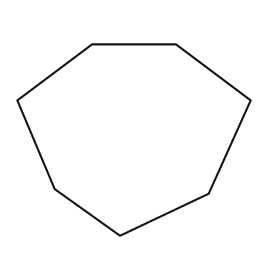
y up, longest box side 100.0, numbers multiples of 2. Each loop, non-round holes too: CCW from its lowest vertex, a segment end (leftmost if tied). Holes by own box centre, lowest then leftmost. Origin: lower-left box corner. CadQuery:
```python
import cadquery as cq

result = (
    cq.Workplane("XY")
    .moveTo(44.0, 0.0)
    .lineTo(82.0, 18.0)
    .lineTo(100.0, 58.0)
    .lineTo(68.0, 82.0)
    .lineTo(32.0, 82.0)
    .lineTo(0.0, 58.0)
    .lineTo(16.0, 20.0)
    .close()
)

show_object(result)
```